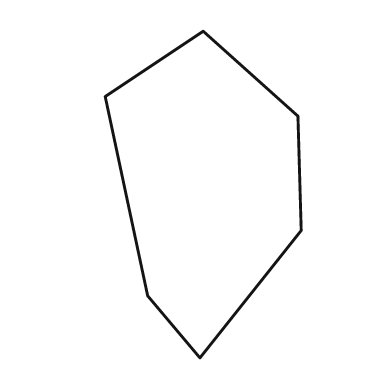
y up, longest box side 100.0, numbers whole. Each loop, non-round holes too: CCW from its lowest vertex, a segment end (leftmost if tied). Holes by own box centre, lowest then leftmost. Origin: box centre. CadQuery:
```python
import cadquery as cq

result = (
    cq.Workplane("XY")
    .moveTo(-1.0, -50.0)
    .lineTo(30.0, -11.0)
    .lineTo(29.0, 24.0)
    .lineTo(0.0, 50.0)
    .lineTo(-30.0, 30.0)
    .lineTo(-17.0, -31.0)
    .close()
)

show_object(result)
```